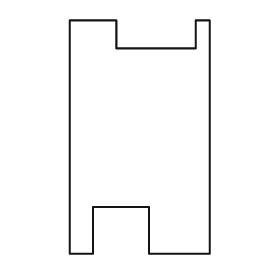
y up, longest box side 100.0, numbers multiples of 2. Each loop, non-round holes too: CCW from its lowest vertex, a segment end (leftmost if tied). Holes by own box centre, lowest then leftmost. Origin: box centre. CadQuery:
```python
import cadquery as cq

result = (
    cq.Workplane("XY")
    .moveTo(-30.0, -50.0)
    .lineTo(-20.0, -50.0)
    .lineTo(-20.0, -30.0)
    .lineTo(4.0, -30.0)
    .lineTo(4.0, -50.0)
    .lineTo(30.0, -50.0)
    .lineTo(30.0, 50.0)
    .lineTo(24.0, 50.0)
    .lineTo(24.0, 38.0)
    .lineTo(-10.0, 38.0)
    .lineTo(-10.0, 50.0)
    .lineTo(-30.0, 50.0)
    .close()
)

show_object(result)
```